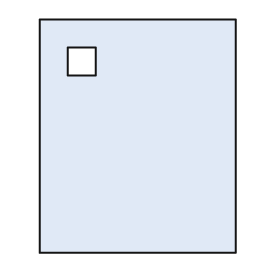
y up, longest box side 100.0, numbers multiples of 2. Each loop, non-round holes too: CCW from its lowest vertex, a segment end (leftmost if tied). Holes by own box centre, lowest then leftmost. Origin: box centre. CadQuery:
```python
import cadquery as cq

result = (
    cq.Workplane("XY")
    .moveTo(-42.0, -50.0)
    .lineTo(42.0, -50.0)
    .lineTo(42.0, 50.0)
    .lineTo(-42.0, 50.0)
    .close()
    .moveTo(-30.0, 26.0)
    .lineTo(-18.0, 26.0)
    .lineTo(-18.0, 38.0)
    .lineTo(-30.0, 38.0)
    .close()
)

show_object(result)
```